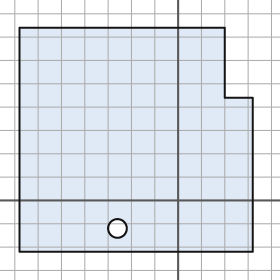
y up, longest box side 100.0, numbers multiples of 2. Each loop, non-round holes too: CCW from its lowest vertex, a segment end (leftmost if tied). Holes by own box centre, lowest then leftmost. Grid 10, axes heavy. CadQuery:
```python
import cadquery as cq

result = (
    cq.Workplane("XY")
    .moveTo(-68.0, -22.0)
    .lineTo(32.0, -22.0)
    .lineTo(32.0, 44.0)
    .lineTo(20.0, 44.0)
    .lineTo(20.0, 74.0)
    .lineTo(-68.0, 74.0)
    .close()
    .moveTo(-26.0, -12.0)
    .circle(4.0)
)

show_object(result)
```